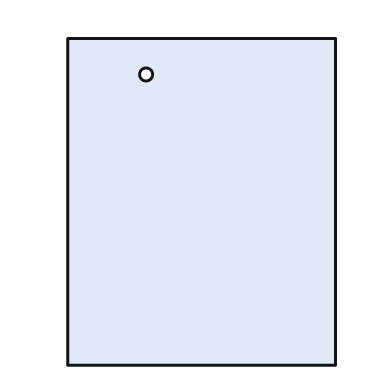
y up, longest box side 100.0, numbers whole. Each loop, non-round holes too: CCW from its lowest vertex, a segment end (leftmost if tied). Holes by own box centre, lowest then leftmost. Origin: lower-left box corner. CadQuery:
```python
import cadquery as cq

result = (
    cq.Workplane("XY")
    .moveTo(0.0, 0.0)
    .lineTo(82.0, 0.0)
    .lineTo(82.0, 100.0)
    .lineTo(0.0, 100.0)
    .close()
    .moveTo(24.0, 89.0)
    .circle(2.0)
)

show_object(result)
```